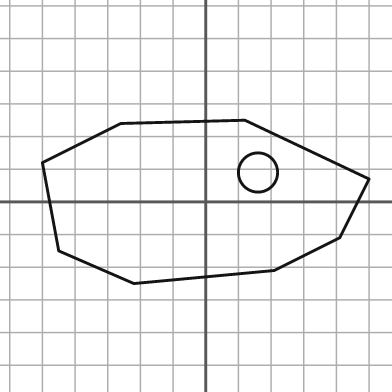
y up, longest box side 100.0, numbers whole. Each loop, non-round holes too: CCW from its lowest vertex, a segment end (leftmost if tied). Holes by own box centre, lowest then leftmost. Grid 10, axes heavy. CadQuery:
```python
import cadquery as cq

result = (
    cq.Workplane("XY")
    .moveTo(-22.0, -25.0)
    .lineTo(21.0, -21.0)
    .lineTo(41.0, -11.0)
    .lineTo(50.0, 7.0)
    .lineTo(12.0, 25.0)
    .lineTo(-26.0, 24.0)
    .lineTo(-50.0, 12.0)
    .lineTo(-45.0, -15.0)
    .close()
    .moveTo(16.0, 9.0)
    .circle(6.0)
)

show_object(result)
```